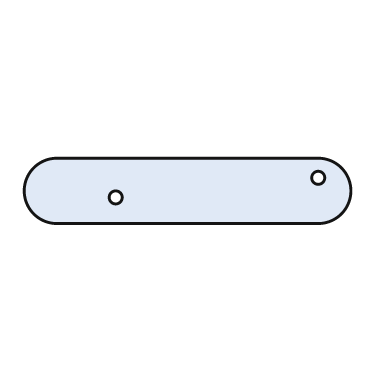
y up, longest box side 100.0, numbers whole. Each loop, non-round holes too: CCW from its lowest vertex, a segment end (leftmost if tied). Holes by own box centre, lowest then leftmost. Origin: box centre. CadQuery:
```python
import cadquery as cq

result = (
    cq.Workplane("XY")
    .moveTo(-40.0, -10.0)
    .lineTo(40.0, -10.0)
    .threePointArc((50.0, 0.0), (40.0, 10.0))
    .lineTo(-40.0, 10.0)
    .threePointArc((-50.0, 0.0), (-40.0, -10.0))
    .close()
    .moveTo(-22.0, -2.0)
    .circle(2.0)
    .moveTo(40.0, 4.0)
    .circle(2.0)
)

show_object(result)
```